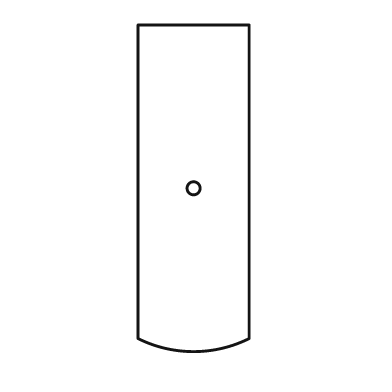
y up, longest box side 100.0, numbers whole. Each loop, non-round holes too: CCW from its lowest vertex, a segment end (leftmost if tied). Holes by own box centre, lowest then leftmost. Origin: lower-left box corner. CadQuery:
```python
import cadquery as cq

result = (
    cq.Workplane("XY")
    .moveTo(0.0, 4.0)
    .threePointArc((17.0, 0.0), (34.0, 4.0))
    .lineTo(34.0, 100.0)
    .lineTo(0.0, 100.0)
    .close()
    .moveTo(17.0, 50.0)
    .circle(2.0)
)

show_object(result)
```